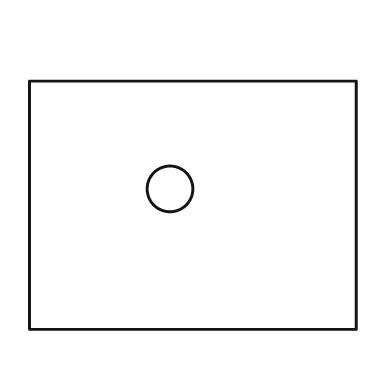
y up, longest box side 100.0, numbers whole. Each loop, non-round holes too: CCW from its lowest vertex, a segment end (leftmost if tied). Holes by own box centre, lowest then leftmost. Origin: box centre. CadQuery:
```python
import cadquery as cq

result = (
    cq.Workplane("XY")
    .moveTo(-50.0, -38.0)
    .lineTo(50.0, -38.0)
    .lineTo(50.0, 38.0)
    .lineTo(-50.0, 38.0)
    .close()
    .moveTo(-7.0, 5.0)
    .circle(7.0)
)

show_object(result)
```